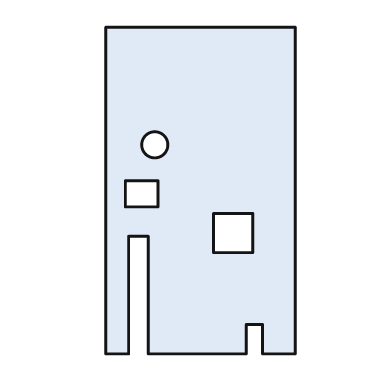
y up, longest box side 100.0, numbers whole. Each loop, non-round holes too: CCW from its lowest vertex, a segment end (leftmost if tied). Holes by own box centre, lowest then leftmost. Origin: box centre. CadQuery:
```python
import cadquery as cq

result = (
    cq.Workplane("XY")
    .moveTo(-29.0, -50.0)
    .lineTo(-22.0, -50.0)
    .lineTo(-22.0, -14.0)
    .lineTo(-16.0, -14.0)
    .lineTo(-16.0, -50.0)
    .lineTo(14.0, -50.0)
    .lineTo(14.0, -41.0)
    .lineTo(19.0, -41.0)
    .lineTo(19.0, -50.0)
    .lineTo(29.0, -50.0)
    .lineTo(29.0, 50.0)
    .lineTo(-29.0, 50.0)
    .close()
    .moveTo(4.0, -19.0)
    .lineTo(16.0, -19.0)
    .lineTo(16.0, -7.0)
    .lineTo(4.0, -7.0)
    .close()
    .moveTo(-23.0, -5.0)
    .lineTo(-13.0, -5.0)
    .lineTo(-13.0, 3.0)
    .lineTo(-23.0, 3.0)
    .close()
    .moveTo(-14.0, 14.0)
    .circle(4.0)
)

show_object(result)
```